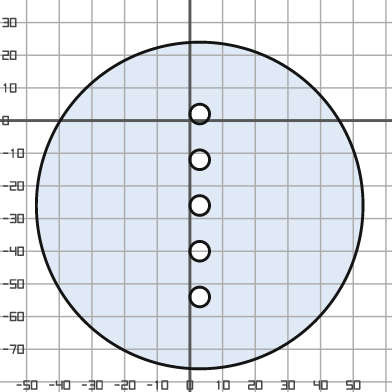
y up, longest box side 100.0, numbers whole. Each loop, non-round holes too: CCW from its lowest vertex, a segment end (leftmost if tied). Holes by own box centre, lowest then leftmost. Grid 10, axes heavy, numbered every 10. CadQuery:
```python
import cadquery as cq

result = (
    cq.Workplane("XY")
    .moveTo(3.0, -26.0)
    .circle(50.0)
    .moveTo(3.0, -54.0)
    .circle(3.0)
    .moveTo(3.0, -40.0)
    .circle(3.0)
    .moveTo(3.0, -26.0)
    .circle(3.0)
    .moveTo(3.0, -12.0)
    .circle(3.0)
    .moveTo(3.0, 2.0)
    .circle(3.0)
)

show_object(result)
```